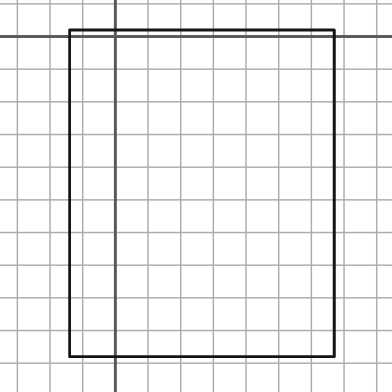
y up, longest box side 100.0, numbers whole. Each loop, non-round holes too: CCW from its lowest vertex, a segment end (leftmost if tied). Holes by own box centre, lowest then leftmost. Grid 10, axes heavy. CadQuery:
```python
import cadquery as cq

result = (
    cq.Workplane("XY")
    .moveTo(-14.0, -98.0)
    .lineTo(67.0, -98.0)
    .lineTo(67.0, 2.0)
    .lineTo(-14.0, 2.0)
    .close()
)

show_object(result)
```